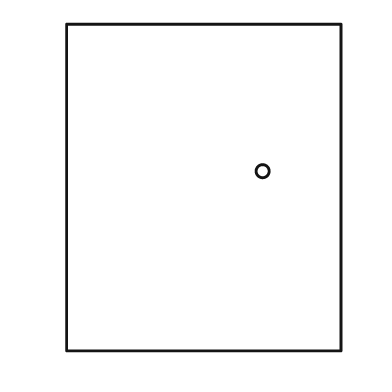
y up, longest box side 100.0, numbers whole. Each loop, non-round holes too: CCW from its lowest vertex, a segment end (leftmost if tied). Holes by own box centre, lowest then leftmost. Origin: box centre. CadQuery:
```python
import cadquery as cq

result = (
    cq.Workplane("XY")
    .moveTo(-42.0, -50.0)
    .lineTo(42.0, -50.0)
    .lineTo(42.0, 50.0)
    .lineTo(-42.0, 50.0)
    .close()
    .moveTo(18.0, 5.0)
    .circle(2.0)
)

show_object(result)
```